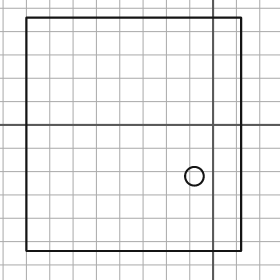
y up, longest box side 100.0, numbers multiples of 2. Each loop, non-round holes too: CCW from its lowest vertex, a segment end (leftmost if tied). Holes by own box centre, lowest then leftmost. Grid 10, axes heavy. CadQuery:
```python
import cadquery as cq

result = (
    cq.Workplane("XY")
    .moveTo(-80.0, -54.0)
    .lineTo(12.0, -54.0)
    .lineTo(12.0, 46.0)
    .lineTo(-80.0, 46.0)
    .close()
    .moveTo(-8.0, -22.0)
    .circle(4.0)
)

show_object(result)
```